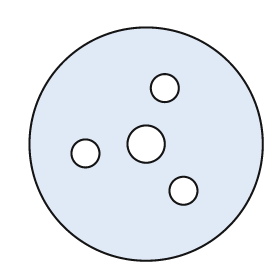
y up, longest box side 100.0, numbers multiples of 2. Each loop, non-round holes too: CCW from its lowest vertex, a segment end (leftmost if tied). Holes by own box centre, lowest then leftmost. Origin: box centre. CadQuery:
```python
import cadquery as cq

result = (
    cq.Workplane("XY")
    .moveTo(0.0, 0.0)
    .circle(50.0)
    .moveTo(16.0, -20.0)
    .circle(6.0)
    .moveTo(-26.0, -4.0)
    .circle(6.0)
    .moveTo(0.0, 0.0)
    .circle(8.0)
    .moveTo(8.0, 24.0)
    .circle(6.0)
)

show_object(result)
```